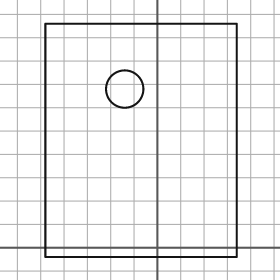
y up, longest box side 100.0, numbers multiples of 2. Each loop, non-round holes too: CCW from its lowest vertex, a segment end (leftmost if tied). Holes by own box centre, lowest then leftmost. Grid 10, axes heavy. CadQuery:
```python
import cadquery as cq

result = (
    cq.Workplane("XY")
    .moveTo(-48.0, -4.0)
    .lineTo(34.0, -4.0)
    .lineTo(34.0, 96.0)
    .lineTo(-48.0, 96.0)
    .close()
    .moveTo(-14.0, 68.0)
    .circle(8.0)
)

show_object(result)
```